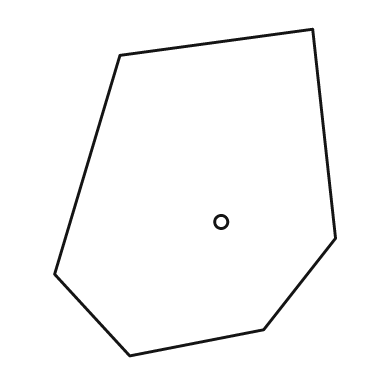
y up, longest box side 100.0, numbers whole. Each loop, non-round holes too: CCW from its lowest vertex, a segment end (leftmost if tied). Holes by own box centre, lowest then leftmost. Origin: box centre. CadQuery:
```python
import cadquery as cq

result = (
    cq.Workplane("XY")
    .moveTo(-20.0, -50.0)
    .lineTo(21.0, -42.0)
    .lineTo(43.0, -14.0)
    .lineTo(36.0, 50.0)
    .lineTo(-23.0, 42.0)
    .lineTo(-43.0, -25.0)
    .close()
    .moveTo(8.0, -9.0)
    .circle(2.0)
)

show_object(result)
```